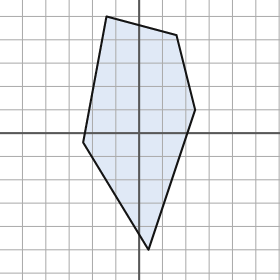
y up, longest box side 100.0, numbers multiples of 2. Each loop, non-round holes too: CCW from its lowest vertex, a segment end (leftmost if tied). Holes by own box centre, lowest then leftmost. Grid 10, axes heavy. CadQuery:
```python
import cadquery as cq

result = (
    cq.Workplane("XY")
    .moveTo(4.0, -50.0)
    .lineTo(24.0, 10.0)
    .lineTo(16.0, 42.0)
    .lineTo(-14.0, 50.0)
    .lineTo(-24.0, -4.0)
    .close()
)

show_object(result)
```